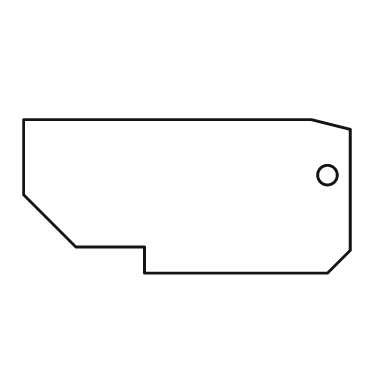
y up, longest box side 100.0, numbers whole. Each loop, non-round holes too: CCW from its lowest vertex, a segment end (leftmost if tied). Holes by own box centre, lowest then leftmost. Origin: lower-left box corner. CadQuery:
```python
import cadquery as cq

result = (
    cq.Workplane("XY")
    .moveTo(37.0, 0.0)
    .lineTo(93.0, 0.0)
    .lineTo(100.0, 7.0)
    .lineTo(100.0, 44.0)
    .lineTo(88.0, 47.0)
    .lineTo(0.0, 47.0)
    .lineTo(0.0, 24.0)
    .lineTo(16.0, 8.0)
    .lineTo(37.0, 8.0)
    .close()
    .moveTo(93.0, 30.0)
    .circle(3.0)
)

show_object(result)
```